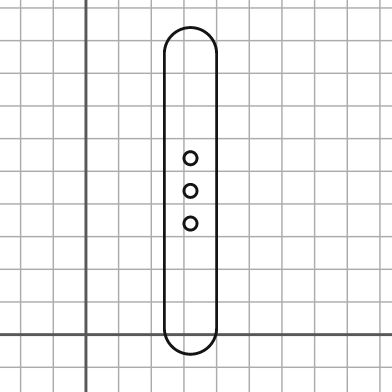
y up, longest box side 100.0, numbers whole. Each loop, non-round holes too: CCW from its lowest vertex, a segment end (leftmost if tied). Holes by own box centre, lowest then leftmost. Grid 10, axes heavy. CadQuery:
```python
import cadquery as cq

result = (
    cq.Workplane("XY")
    .moveTo(24.0, 2.0)
    .threePointArc((32.0, -6.0), (40.0, 2.0))
    .lineTo(40.0, 86.0)
    .threePointArc((32.0, 94.0), (24.0, 86.0))
    .close()
    .moveTo(32.0, 34.0)
    .circle(2.0)
    .moveTo(32.0, 44.0)
    .circle(2.0)
    .moveTo(32.0, 54.0)
    .circle(2.0)
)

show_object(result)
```